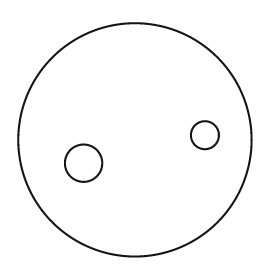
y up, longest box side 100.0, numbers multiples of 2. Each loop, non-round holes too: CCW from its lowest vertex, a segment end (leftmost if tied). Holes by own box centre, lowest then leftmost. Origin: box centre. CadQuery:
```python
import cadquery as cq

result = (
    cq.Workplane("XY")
    .moveTo(0.0, 0.0)
    .circle(50.0)
    .moveTo(-22.0, -10.0)
    .circle(8.0)
    .moveTo(30.0, 2.0)
    .circle(6.0)
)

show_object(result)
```